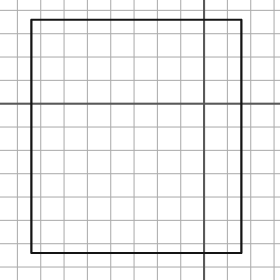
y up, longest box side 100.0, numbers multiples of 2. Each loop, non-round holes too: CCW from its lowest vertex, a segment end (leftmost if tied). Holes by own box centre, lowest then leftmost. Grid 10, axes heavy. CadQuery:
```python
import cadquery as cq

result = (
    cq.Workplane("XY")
    .moveTo(-74.0, -64.0)
    .lineTo(16.0, -64.0)
    .lineTo(16.0, 36.0)
    .lineTo(-74.0, 36.0)
    .close()
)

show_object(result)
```